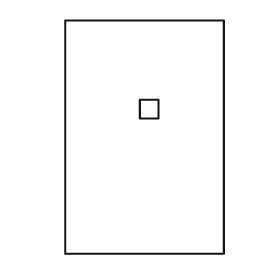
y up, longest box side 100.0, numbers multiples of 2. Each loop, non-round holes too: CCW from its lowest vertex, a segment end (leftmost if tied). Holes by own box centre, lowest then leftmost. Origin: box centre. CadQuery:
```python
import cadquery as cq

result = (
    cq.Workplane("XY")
    .moveTo(-34.0, -50.0)
    .lineTo(34.0, -50.0)
    .lineTo(34.0, 50.0)
    .lineTo(-34.0, 50.0)
    .close()
    .moveTo(-2.0, 8.0)
    .lineTo(6.0, 8.0)
    .lineTo(6.0, 16.0)
    .lineTo(-2.0, 16.0)
    .close()
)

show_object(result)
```